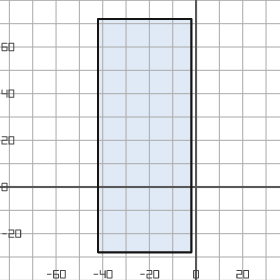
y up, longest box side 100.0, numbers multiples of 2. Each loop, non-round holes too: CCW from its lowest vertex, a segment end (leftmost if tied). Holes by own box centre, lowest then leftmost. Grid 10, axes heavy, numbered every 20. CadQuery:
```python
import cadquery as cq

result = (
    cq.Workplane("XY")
    .moveTo(-42.0, -28.0)
    .lineTo(-2.0, -28.0)
    .lineTo(-2.0, 72.0)
    .lineTo(-42.0, 72.0)
    .close()
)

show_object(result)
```